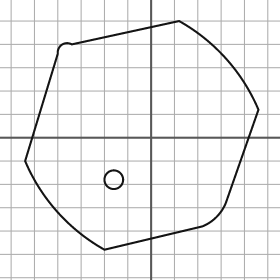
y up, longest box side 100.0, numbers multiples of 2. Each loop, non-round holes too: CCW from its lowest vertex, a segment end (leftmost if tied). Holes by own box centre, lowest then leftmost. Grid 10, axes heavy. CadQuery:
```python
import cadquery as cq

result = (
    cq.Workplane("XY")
    .moveTo(-20.0, -48.0)
    .lineTo(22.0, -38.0)
    .threePointArc((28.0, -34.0), (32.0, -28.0))
    .lineTo(46.0, 12.0)
    .threePointArc((32.0, 34.0), (12.0, 50.0))
    .lineTo(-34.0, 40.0)
    .threePointArc((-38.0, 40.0), (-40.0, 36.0))
    .lineTo(-54.0, -10.0)
    .threePointArc((-40.0, -32.0), (-20.0, -48.0))
    .close()
    .moveTo(-16.0, -18.0)
    .circle(4.0)
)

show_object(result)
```